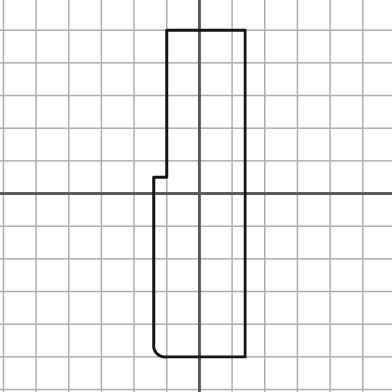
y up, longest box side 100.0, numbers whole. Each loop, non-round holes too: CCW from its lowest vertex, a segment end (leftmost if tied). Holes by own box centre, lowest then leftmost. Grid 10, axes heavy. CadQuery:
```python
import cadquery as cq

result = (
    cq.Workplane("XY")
    .moveTo(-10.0, -50.0)
    .lineTo(14.0, -50.0)
    .lineTo(14.0, 50.0)
    .lineTo(-10.0, 50.0)
    .lineTo(-10.0, 5.0)
    .lineTo(-14.0, 5.0)
    .lineTo(-14.0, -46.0)
    .threePointArc((-13.0, -49.0), (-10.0, -50.0))
    .close()
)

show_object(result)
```